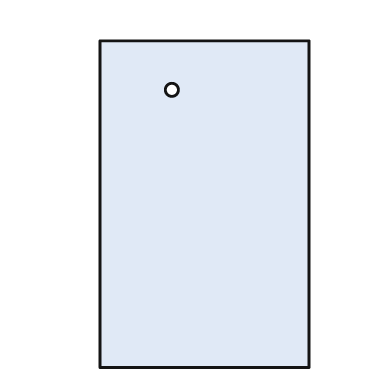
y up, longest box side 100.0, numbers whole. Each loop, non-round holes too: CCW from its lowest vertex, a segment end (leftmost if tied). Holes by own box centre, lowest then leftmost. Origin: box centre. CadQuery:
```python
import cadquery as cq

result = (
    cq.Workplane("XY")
    .moveTo(-32.0, -50.0)
    .lineTo(32.0, -50.0)
    .lineTo(32.0, 50.0)
    .lineTo(-32.0, 50.0)
    .close()
    .moveTo(-10.0, 35.0)
    .circle(2.0)
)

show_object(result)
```